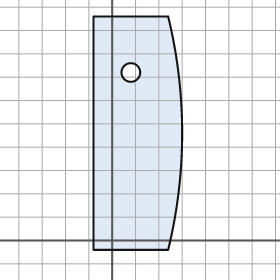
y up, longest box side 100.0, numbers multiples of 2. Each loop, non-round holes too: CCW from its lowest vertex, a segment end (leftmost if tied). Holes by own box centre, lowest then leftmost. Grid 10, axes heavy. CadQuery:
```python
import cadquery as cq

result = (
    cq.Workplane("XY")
    .moveTo(-8.0, -4.0)
    .lineTo(24.0, -4.0)
    .threePointArc((30.0, 46.0), (24.0, 96.0))
    .lineTo(-8.0, 96.0)
    .close()
    .moveTo(8.0, 72.0)
    .circle(4.0)
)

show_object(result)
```